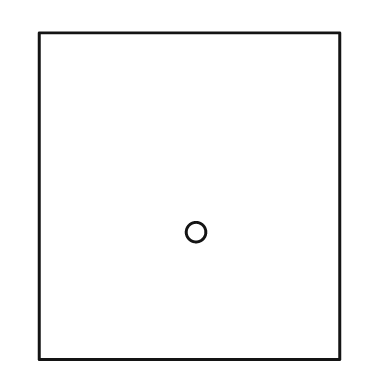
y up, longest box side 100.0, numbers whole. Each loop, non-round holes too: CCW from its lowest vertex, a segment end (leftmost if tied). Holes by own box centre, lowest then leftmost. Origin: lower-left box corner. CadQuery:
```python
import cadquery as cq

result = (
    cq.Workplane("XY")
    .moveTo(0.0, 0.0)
    .lineTo(92.0, 0.0)
    .lineTo(92.0, 100.0)
    .lineTo(0.0, 100.0)
    .close()
    .moveTo(48.0, 39.0)
    .circle(3.0)
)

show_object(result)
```